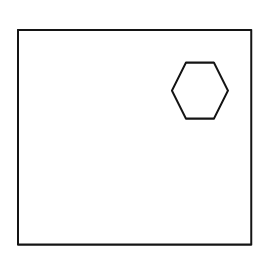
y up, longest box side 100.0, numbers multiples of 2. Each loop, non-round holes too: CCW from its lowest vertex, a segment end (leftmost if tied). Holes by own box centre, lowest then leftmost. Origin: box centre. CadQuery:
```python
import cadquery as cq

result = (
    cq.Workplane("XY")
    .moveTo(-50.0, -46.0)
    .lineTo(50.0, -46.0)
    .lineTo(50.0, 46.0)
    .lineTo(-50.0, 46.0)
    .close()
    .moveTo(22.0, 8.0)
    .lineTo(34.0, 8.0)
    .lineTo(40.0, 20.0)
    .lineTo(34.0, 32.0)
    .lineTo(22.0, 32.0)
    .lineTo(16.0, 20.0)
    .close()
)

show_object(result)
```